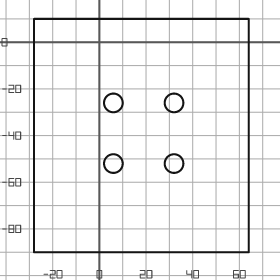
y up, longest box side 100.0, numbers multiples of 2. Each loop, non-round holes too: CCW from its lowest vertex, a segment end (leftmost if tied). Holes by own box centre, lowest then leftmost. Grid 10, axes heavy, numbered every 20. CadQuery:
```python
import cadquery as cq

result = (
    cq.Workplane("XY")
    .moveTo(-28.0, -90.0)
    .lineTo(64.0, -90.0)
    .lineTo(64.0, 10.0)
    .lineTo(-28.0, 10.0)
    .close()
    .moveTo(6.0, -52.0)
    .circle(4.0)
    .moveTo(32.0, -52.0)
    .circle(4.0)
    .moveTo(6.0, -26.0)
    .circle(4.0)
    .moveTo(32.0, -26.0)
    .circle(4.0)
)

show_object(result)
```